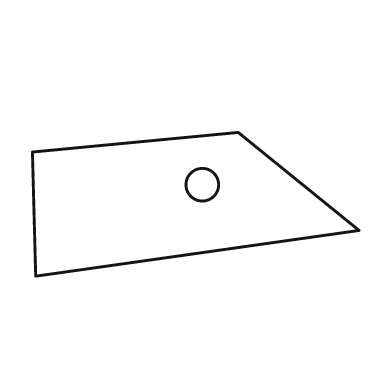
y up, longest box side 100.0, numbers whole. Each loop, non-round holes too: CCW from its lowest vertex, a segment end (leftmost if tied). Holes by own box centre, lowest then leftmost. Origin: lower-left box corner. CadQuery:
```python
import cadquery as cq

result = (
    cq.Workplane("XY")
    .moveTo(1.0, 0.0)
    .lineTo(100.0, 14.0)
    .lineTo(63.0, 44.0)
    .lineTo(0.0, 38.0)
    .close()
    .moveTo(52.0, 28.0)
    .circle(5.0)
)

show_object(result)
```